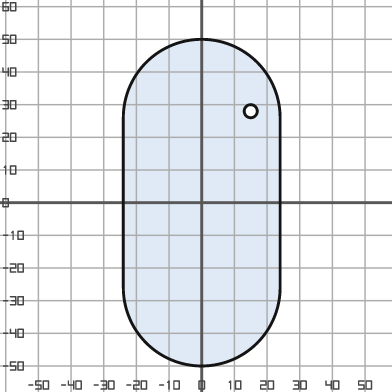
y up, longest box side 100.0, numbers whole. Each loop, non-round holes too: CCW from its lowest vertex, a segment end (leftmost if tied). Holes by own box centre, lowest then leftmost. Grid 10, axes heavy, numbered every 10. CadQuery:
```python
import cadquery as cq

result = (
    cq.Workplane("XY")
    .moveTo(-24.0, -26.0)
    .threePointArc((0.0, -50.0), (24.0, -26.0))
    .lineTo(24.0, 26.0)
    .threePointArc((0.0, 50.0), (-24.0, 26.0))
    .close()
    .moveTo(15.0, 28.0)
    .circle(2.0)
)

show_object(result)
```